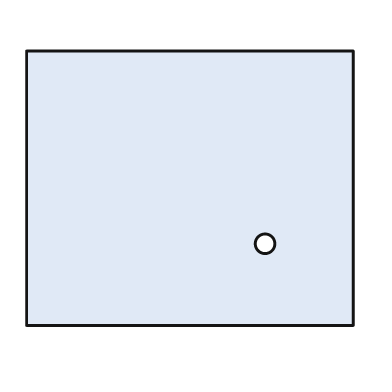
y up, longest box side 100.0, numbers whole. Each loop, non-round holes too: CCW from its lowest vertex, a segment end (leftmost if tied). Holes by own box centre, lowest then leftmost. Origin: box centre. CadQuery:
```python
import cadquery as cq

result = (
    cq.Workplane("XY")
    .moveTo(-50.0, -42.0)
    .lineTo(50.0, -42.0)
    .lineTo(50.0, 42.0)
    .lineTo(-50.0, 42.0)
    .close()
    .moveTo(23.0, -17.0)
    .circle(3.0)
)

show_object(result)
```